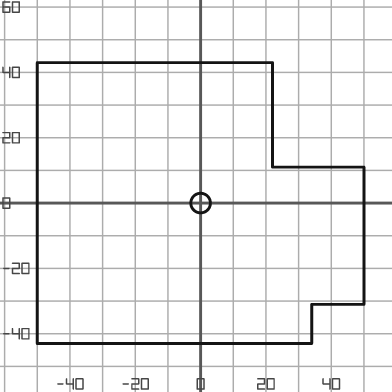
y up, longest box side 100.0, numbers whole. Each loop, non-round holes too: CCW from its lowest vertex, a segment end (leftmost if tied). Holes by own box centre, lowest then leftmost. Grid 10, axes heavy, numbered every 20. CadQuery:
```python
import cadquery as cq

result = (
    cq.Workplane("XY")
    .moveTo(-50.0, -43.0)
    .lineTo(34.0, -43.0)
    .lineTo(34.0, -31.0)
    .lineTo(50.0, -31.0)
    .lineTo(50.0, 11.0)
    .lineTo(22.0, 11.0)
    .lineTo(22.0, 43.0)
    .lineTo(-50.0, 43.0)
    .close()
    .moveTo(0.0, 0.0)
    .circle(3.0)
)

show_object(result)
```